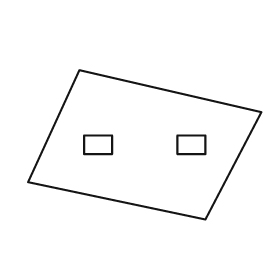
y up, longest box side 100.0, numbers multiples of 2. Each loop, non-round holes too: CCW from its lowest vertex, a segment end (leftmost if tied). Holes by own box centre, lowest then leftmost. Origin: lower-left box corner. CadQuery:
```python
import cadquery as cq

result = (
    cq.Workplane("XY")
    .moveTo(76.0, 0.0)
    .lineTo(100.0, 46.0)
    .lineTo(22.0, 64.0)
    .lineTo(0.0, 16.0)
    .close()
    .moveTo(24.0, 28.0)
    .lineTo(36.0, 28.0)
    .lineTo(36.0, 36.0)
    .lineTo(24.0, 36.0)
    .close()
    .moveTo(64.0, 28.0)
    .lineTo(76.0, 28.0)
    .lineTo(76.0, 36.0)
    .lineTo(64.0, 36.0)
    .close()
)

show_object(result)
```